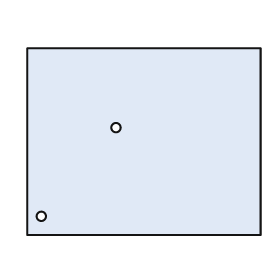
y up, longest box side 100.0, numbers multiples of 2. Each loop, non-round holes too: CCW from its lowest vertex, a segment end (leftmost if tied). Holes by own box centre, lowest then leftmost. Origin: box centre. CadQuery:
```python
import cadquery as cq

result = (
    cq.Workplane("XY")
    .moveTo(-50.0, -40.0)
    .lineTo(50.0, -40.0)
    .lineTo(50.0, 40.0)
    .lineTo(-50.0, 40.0)
    .close()
    .moveTo(-44.0, -32.0)
    .circle(2.0)
    .moveTo(-12.0, 6.0)
    .circle(2.0)
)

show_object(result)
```